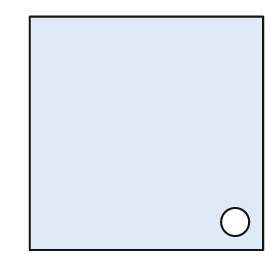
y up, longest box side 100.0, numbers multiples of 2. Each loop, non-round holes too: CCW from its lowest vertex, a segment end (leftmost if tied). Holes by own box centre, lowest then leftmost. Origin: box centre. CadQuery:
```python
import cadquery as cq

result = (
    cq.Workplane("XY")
    .moveTo(-50.0, -50.0)
    .lineTo(50.0, -50.0)
    .lineTo(50.0, 50.0)
    .lineTo(-50.0, 50.0)
    .close()
    .moveTo(38.0, -38.0)
    .circle(6.0)
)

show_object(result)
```